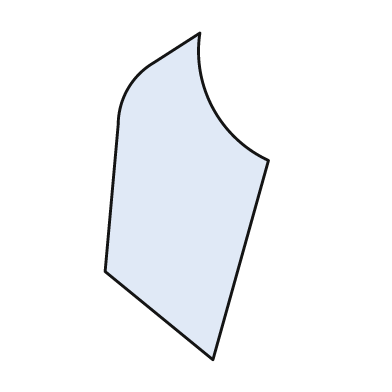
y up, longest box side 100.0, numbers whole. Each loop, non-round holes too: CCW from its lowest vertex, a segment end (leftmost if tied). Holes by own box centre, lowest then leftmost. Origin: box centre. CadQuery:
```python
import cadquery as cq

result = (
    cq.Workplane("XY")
    .moveTo(8.0, -50.0)
    .lineTo(25.0, 11.0)
    .threePointArc((8.0, 27.0), (4.0, 50.0))
    .lineTo(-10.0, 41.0)
    .threePointArc((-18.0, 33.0), (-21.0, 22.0))
    .lineTo(-25.0, -23.0)
    .close()
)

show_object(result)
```